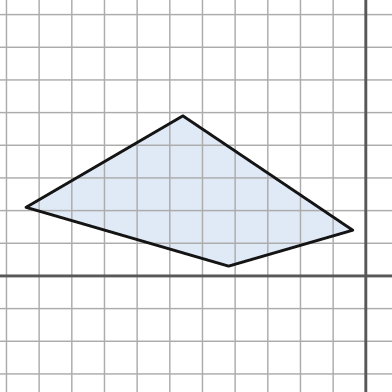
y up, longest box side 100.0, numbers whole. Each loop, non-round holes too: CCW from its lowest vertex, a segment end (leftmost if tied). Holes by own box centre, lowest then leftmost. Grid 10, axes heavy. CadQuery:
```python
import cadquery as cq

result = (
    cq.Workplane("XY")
    .moveTo(-42.0, 3.0)
    .lineTo(-4.0, 14.0)
    .lineTo(-56.0, 49.0)
    .lineTo(-104.0, 21.0)
    .close()
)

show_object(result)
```